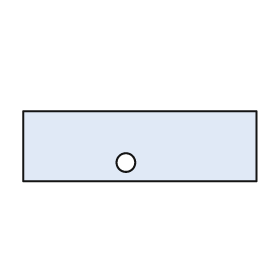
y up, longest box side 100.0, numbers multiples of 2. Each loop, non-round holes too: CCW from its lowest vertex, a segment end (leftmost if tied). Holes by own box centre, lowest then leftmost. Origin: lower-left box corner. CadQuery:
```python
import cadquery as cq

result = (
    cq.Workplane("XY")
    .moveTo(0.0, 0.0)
    .lineTo(100.0, 0.0)
    .lineTo(100.0, 30.0)
    .lineTo(0.0, 30.0)
    .close()
    .moveTo(44.0, 8.0)
    .circle(4.0)
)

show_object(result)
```